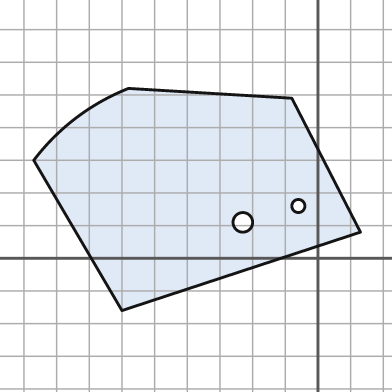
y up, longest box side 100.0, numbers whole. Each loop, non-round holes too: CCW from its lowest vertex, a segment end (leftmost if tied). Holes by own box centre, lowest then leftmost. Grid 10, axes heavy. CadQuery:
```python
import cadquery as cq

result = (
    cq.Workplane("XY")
    .moveTo(-60.0, -16.0)
    .lineTo(13.0, 8.0)
    .lineTo(-8.0, 49.0)
    .lineTo(-58.0, 52.0)
    .threePointArc((-74.0, 43.0), (-87.0, 30.0))
    .close()
    .moveTo(-23.0, 11.0)
    .circle(3.0)
    .moveTo(-6.0, 16.0)
    .circle(2.0)
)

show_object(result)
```